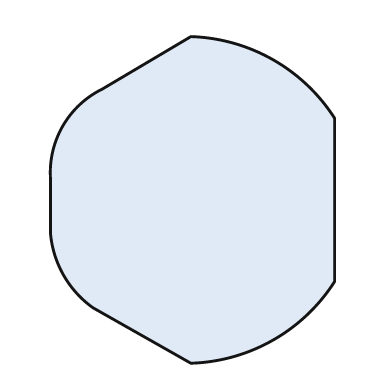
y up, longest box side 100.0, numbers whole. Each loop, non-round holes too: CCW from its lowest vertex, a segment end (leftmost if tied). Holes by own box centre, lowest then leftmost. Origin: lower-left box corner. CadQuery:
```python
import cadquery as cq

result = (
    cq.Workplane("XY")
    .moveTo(43.0, 0.0)
    .threePointArc((68.0, 7.0), (87.0, 25.0))
    .lineTo(87.0, 75.0)
    .threePointArc((68.0, 93.0), (43.0, 100.0))
    .lineTo(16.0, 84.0)
    .threePointArc((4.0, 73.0), (0.0, 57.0))
    .lineTo(0.0, 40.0)
    .threePointArc((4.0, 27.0), (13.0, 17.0))
    .close()
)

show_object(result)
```